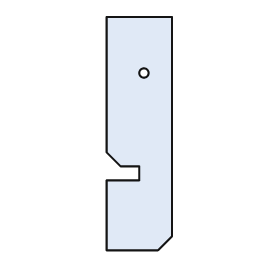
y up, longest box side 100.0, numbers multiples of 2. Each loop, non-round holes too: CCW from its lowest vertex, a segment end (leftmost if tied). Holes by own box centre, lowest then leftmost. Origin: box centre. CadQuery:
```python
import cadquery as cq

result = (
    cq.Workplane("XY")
    .moveTo(-14.0, -50.0)
    .lineTo(8.0, -50.0)
    .lineTo(14.0, -44.0)
    .lineTo(14.0, 50.0)
    .lineTo(-14.0, 50.0)
    .lineTo(-14.0, -8.0)
    .lineTo(-8.0, -14.0)
    .lineTo(0.0, -14.0)
    .lineTo(0.0, -20.0)
    .lineTo(-14.0, -20.0)
    .close()
    .moveTo(2.0, 26.0)
    .circle(2.0)
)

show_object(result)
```